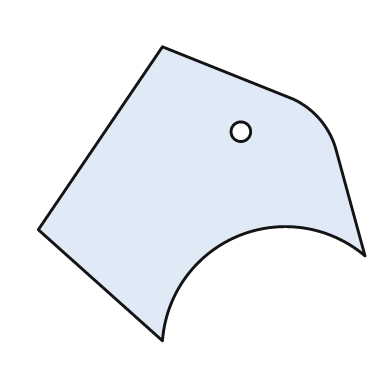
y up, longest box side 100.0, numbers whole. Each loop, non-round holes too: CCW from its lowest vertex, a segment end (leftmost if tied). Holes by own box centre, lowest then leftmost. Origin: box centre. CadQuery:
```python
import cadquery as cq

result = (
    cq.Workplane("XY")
    .moveTo(-12.0, -45.0)
    .threePointArc((11.0, -13.0), (50.0, -19.0))
    .lineTo(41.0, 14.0)
    .threePointArc((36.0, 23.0), (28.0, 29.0))
    .lineTo(-12.0, 45.0)
    .lineTo(-50.0, -11.0)
    .close()
    .moveTo(12.0, 19.0)
    .circle(3.0)
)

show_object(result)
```